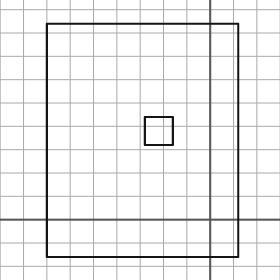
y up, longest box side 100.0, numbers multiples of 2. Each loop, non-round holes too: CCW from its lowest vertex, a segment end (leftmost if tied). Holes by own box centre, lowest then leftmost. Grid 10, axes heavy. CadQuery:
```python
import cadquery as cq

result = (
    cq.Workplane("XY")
    .moveTo(-70.0, -16.0)
    .lineTo(12.0, -16.0)
    .lineTo(12.0, 84.0)
    .lineTo(-70.0, 84.0)
    .close()
    .moveTo(-28.0, 32.0)
    .lineTo(-16.0, 32.0)
    .lineTo(-16.0, 44.0)
    .lineTo(-28.0, 44.0)
    .close()
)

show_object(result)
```